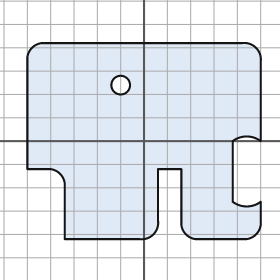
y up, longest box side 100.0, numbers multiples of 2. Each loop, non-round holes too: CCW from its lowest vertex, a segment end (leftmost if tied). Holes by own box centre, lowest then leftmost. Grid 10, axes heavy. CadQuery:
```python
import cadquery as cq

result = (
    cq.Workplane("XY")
    .moveTo(-34.0, -42.0)
    .lineTo(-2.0, -42.0)
    .threePointArc((4.0, -40.0), (6.0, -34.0))
    .lineTo(6.0, -12.0)
    .lineTo(16.0, -12.0)
    .lineTo(16.0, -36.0)
    .threePointArc((18.0, -40.0), (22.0, -42.0))
    .lineTo(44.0, -42.0)
    .threePointArc((48.0, -40.0), (50.0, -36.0))
    .lineTo(50.0, -26.0)
    .threePointArc((44.0, -28.0), (38.0, -26.0))
    .lineTo(38.0, 0.0)
    .threePointArc((44.0, 2.0), (50.0, 0.0))
    .lineTo(50.0, 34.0)
    .threePointArc((48.0, 40.0), (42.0, 42.0))
    .lineTo(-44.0, 42.0)
    .threePointArc((-48.0, 40.0), (-50.0, 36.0))
    .lineTo(-50.0, -12.0)
    .lineTo(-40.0, -12.0)
    .threePointArc((-36.0, -14.0), (-34.0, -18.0))
    .close()
    .moveTo(-10.0, 24.0)
    .circle(4.0)
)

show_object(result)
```